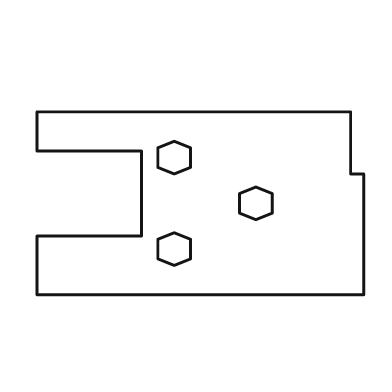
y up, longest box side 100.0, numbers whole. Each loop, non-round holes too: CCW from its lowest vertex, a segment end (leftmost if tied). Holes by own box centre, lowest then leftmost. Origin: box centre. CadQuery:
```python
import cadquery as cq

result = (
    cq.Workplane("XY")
    .moveTo(-50.0, -28.0)
    .lineTo(50.0, -28.0)
    .lineTo(50.0, 9.0)
    .lineTo(46.0, 9.0)
    .lineTo(46.0, 28.0)
    .lineTo(-50.0, 28.0)
    .lineTo(-50.0, 16.0)
    .lineTo(-18.0, 16.0)
    .lineTo(-18.0, -10.0)
    .lineTo(-50.0, -10.0)
    .close()
    .moveTo(-8.0, -19.0)
    .lineTo(-3.0, -17.0)
    .lineTo(-3.0, -11.0)
    .lineTo(-8.0, -9.0)
    .lineTo(-13.0, -11.0)
    .lineTo(-13.0, -17.0)
    .close()
    .moveTo(17.0, -5.0)
    .lineTo(22.0, -3.0)
    .lineTo(22.0, 3.0)
    .lineTo(17.0, 5.0)
    .lineTo(12.0, 3.0)
    .lineTo(12.0, -3.0)
    .close()
    .moveTo(-8.0, 9.0)
    .lineTo(-3.0, 11.0)
    .lineTo(-3.0, 17.0)
    .lineTo(-8.0, 19.0)
    .lineTo(-13.0, 17.0)
    .lineTo(-13.0, 11.0)
    .close()
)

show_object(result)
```